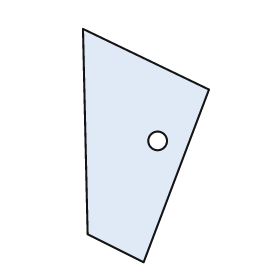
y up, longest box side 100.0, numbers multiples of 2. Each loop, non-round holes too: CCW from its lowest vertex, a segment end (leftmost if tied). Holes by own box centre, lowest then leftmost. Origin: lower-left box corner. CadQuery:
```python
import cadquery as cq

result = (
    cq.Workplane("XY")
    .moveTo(26.0, 0.0)
    .lineTo(54.0, 74.0)
    .lineTo(0.0, 100.0)
    .lineTo(2.0, 12.0)
    .close()
    .moveTo(32.0, 52.0)
    .circle(4.0)
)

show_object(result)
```